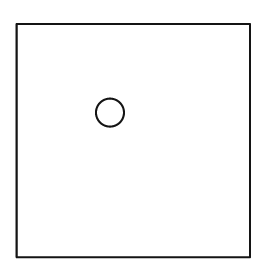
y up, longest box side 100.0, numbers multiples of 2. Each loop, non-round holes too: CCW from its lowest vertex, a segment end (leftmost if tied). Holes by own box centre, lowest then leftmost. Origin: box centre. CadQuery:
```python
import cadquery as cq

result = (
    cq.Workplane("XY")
    .moveTo(-50.0, -50.0)
    .lineTo(50.0, -50.0)
    .lineTo(50.0, 50.0)
    .lineTo(-50.0, 50.0)
    .close()
    .moveTo(-10.0, 12.0)
    .circle(6.0)
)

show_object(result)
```